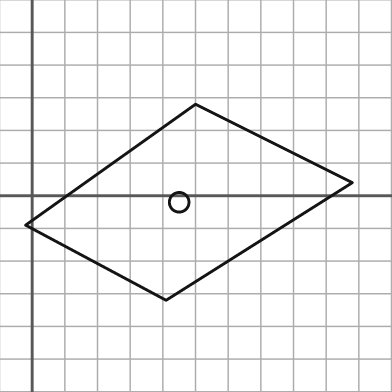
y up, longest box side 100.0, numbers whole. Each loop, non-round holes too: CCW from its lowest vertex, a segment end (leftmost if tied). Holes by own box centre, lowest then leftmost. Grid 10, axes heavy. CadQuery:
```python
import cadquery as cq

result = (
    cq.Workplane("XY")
    .moveTo(41.0, -32.0)
    .lineTo(98.0, 4.0)
    .lineTo(50.0, 28.0)
    .lineTo(-2.0, -9.0)
    .close()
    .moveTo(45.0, -2.0)
    .circle(3.0)
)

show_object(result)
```